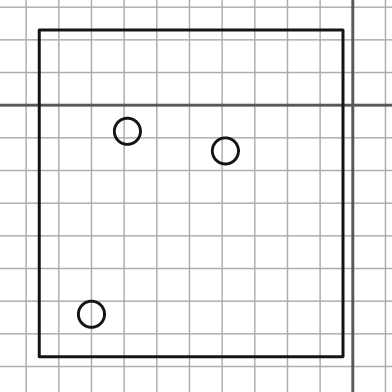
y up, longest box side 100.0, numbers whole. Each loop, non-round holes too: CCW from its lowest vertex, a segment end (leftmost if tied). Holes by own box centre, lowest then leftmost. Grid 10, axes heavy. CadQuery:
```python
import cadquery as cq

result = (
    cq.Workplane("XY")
    .moveTo(-96.0, -77.0)
    .lineTo(-3.0, -77.0)
    .lineTo(-3.0, 23.0)
    .lineTo(-96.0, 23.0)
    .close()
    .moveTo(-80.0, -64.0)
    .circle(4.0)
    .moveTo(-39.0, -14.0)
    .circle(4.0)
    .moveTo(-69.0, -8.0)
    .circle(4.0)
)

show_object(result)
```